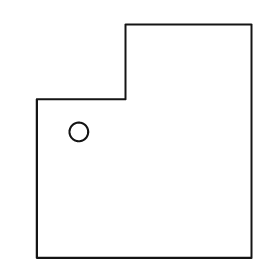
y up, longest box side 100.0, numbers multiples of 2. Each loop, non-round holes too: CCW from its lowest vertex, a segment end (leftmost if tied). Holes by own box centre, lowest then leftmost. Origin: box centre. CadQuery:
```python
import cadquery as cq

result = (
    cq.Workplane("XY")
    .moveTo(-46.0, -50.0)
    .lineTo(46.0, -50.0)
    .lineTo(46.0, 50.0)
    .lineTo(-8.0, 50.0)
    .lineTo(-8.0, 18.0)
    .lineTo(-46.0, 18.0)
    .close()
    .moveTo(-28.0, 4.0)
    .circle(4.0)
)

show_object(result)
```